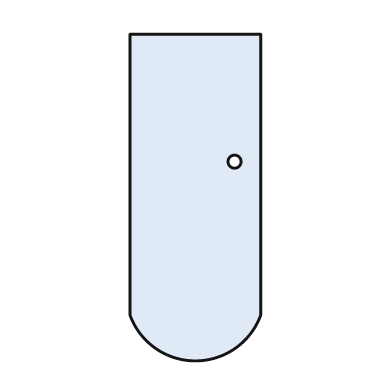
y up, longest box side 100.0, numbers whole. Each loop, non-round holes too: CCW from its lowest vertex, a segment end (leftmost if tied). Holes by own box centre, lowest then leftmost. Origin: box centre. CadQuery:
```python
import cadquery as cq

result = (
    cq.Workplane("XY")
    .moveTo(-20.0, -36.0)
    .threePointArc((0.0, -50.0), (20.0, -36.0))
    .lineTo(20.0, 50.0)
    .lineTo(-20.0, 50.0)
    .close()
    .moveTo(12.0, 11.0)
    .circle(2.0)
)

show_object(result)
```